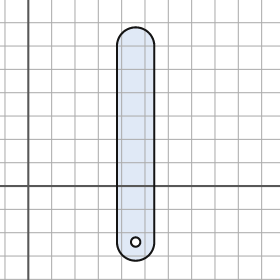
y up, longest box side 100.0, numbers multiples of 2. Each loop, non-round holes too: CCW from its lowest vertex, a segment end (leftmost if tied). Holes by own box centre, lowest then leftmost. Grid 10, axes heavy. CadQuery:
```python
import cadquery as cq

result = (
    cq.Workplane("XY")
    .moveTo(38.0, -24.0)
    .threePointArc((46.0, -32.0), (54.0, -24.0))
    .lineTo(54.0, 60.0)
    .threePointArc((46.0, 68.0), (38.0, 60.0))
    .close()
    .moveTo(46.0, -24.0)
    .circle(2.0)
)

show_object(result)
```